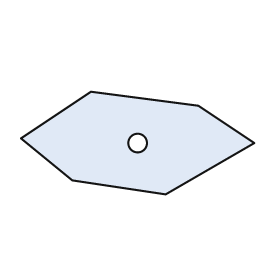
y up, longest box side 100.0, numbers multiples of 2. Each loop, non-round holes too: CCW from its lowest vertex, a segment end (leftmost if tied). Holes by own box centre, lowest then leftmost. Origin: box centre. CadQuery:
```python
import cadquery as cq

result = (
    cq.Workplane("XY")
    .moveTo(12.0, -22.0)
    .lineTo(50.0, 0.0)
    .lineTo(26.0, 16.0)
    .lineTo(-20.0, 22.0)
    .lineTo(-50.0, 2.0)
    .lineTo(-28.0, -16.0)
    .close()
    .moveTo(0.0, 0.0)
    .circle(4.0)
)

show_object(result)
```